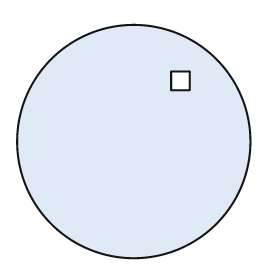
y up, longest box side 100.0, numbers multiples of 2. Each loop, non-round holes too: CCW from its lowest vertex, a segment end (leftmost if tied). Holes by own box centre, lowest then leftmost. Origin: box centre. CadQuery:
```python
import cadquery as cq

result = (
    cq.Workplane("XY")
    .moveTo(0.0, 0.0)
    .circle(50.0)
    .moveTo(16.0, 22.0)
    .lineTo(24.0, 22.0)
    .lineTo(24.0, 30.0)
    .lineTo(16.0, 30.0)
    .close()
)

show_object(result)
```